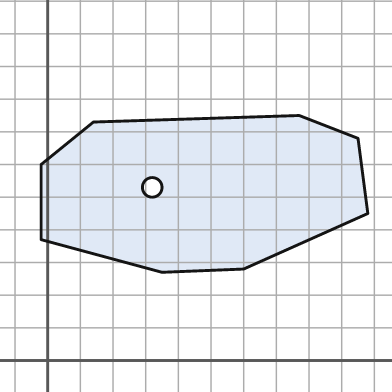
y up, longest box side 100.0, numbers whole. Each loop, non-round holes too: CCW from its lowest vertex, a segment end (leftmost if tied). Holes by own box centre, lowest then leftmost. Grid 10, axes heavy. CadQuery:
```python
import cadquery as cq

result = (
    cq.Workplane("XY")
    .moveTo(35.0, 27.0)
    .lineTo(60.0, 28.0)
    .lineTo(98.0, 45.0)
    .lineTo(95.0, 68.0)
    .lineTo(77.0, 75.0)
    .lineTo(14.0, 73.0)
    .lineTo(-2.0, 60.0)
    .lineTo(-2.0, 37.0)
    .close()
    .moveTo(32.0, 53.0)
    .circle(3.0)
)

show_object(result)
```